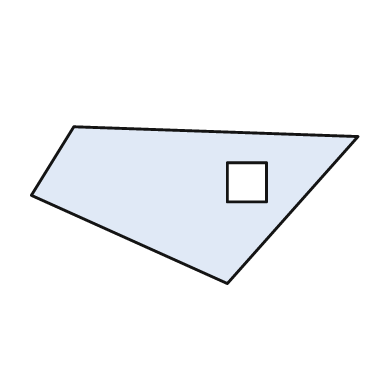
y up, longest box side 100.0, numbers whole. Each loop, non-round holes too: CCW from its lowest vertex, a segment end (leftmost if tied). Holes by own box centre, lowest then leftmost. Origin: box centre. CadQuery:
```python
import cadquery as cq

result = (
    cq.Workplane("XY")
    .moveTo(10.0, -24.0)
    .lineTo(50.0, 21.0)
    .lineTo(-37.0, 24.0)
    .lineTo(-50.0, 3.0)
    .close()
    .moveTo(10.0, 1.0)
    .lineTo(22.0, 1.0)
    .lineTo(22.0, 13.0)
    .lineTo(10.0, 13.0)
    .close()
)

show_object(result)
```